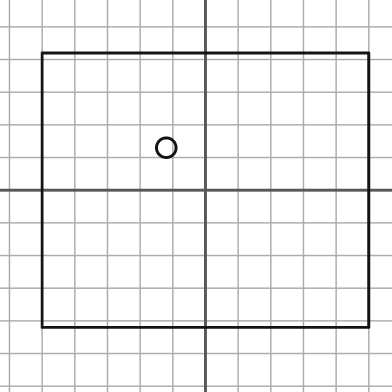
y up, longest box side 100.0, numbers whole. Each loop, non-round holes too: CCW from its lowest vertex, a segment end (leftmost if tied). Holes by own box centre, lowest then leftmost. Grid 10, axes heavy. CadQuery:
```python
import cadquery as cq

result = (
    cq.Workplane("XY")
    .moveTo(-50.0, -42.0)
    .lineTo(50.0, -42.0)
    .lineTo(50.0, 42.0)
    .lineTo(-50.0, 42.0)
    .close()
    .moveTo(-12.0, 13.0)
    .circle(3.0)
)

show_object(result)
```